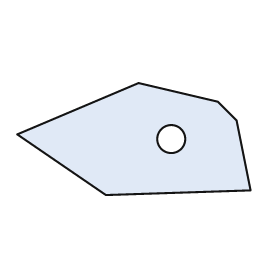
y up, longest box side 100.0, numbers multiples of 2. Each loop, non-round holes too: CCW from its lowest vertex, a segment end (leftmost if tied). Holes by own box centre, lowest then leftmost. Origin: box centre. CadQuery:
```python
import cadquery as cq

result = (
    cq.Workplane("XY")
    .moveTo(-12.0, -24.0)
    .lineTo(50.0, -22.0)
    .lineTo(44.0, 8.0)
    .lineTo(36.0, 16.0)
    .lineTo(2.0, 24.0)
    .lineTo(-50.0, 2.0)
    .close()
    .moveTo(16.0, 0.0)
    .circle(6.0)
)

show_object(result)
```